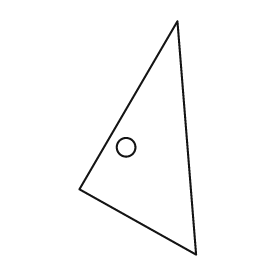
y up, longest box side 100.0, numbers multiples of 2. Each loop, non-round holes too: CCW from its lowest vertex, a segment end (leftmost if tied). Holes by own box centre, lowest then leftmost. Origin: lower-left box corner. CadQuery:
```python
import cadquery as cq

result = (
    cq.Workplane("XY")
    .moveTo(50.0, 0.0)
    .lineTo(42.0, 100.0)
    .lineTo(0.0, 28.0)
    .close()
    .moveTo(20.0, 46.0)
    .circle(4.0)
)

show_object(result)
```